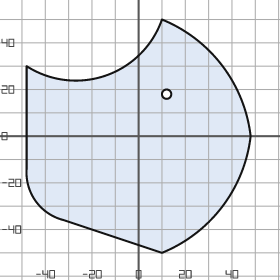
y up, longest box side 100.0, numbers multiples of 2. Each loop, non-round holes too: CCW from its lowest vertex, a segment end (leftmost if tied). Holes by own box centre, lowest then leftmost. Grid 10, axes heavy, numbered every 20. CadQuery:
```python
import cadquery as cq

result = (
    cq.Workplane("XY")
    .moveTo(10.0, -50.0)
    .threePointArc((36.0, -30.0), (48.0, 0.0))
    .threePointArc((36.0, 30.0), (10.0, 50.0))
    .threePointArc((-14.0, 26.0), (-48.0, 30.0))
    .lineTo(-48.0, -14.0)
    .threePointArc((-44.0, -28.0), (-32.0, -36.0))
    .close()
    .moveTo(12.0, 18.0)
    .circle(2.0)
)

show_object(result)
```